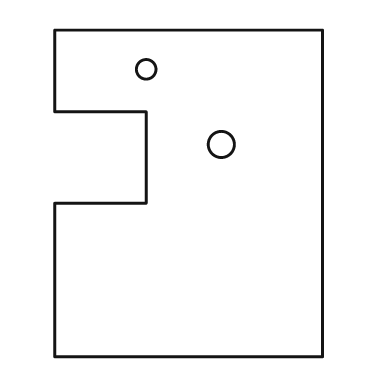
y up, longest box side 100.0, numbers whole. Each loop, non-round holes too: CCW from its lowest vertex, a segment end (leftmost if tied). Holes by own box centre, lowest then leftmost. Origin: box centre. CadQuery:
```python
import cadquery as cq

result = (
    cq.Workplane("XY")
    .moveTo(-41.0, -50.0)
    .lineTo(41.0, -50.0)
    .lineTo(41.0, 50.0)
    .lineTo(-41.0, 50.0)
    .lineTo(-41.0, 25.0)
    .lineTo(-13.0, 25.0)
    .lineTo(-13.0, -3.0)
    .lineTo(-41.0, -3.0)
    .close()
    .moveTo(10.0, 15.0)
    .circle(4.0)
    .moveTo(-13.0, 38.0)
    .circle(3.0)
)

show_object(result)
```